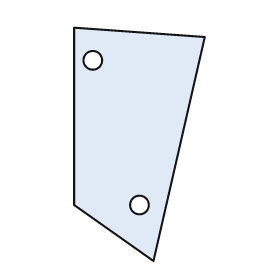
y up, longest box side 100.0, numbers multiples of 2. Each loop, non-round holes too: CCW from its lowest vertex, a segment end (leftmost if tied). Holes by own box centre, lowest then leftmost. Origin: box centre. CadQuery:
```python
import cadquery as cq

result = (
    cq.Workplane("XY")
    .moveTo(6.0, -50.0)
    .lineTo(28.0, 46.0)
    .lineTo(-28.0, 50.0)
    .lineTo(-28.0, -26.0)
    .close()
    .moveTo(0.0, -26.0)
    .circle(4.0)
    .moveTo(-20.0, 36.0)
    .circle(4.0)
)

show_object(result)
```